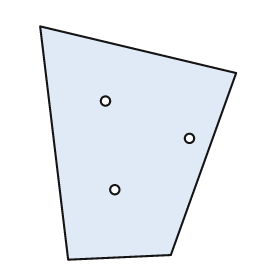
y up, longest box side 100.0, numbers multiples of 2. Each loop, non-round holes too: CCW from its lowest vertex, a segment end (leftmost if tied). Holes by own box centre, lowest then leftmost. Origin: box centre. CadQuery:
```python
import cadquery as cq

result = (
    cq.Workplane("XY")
    .moveTo(-30.0, -50.0)
    .lineTo(14.0, -48.0)
    .lineTo(42.0, 30.0)
    .lineTo(-42.0, 50.0)
    .close()
    .moveTo(-10.0, -20.0)
    .circle(2.0)
    .moveTo(22.0, 2.0)
    .circle(2.0)
    .moveTo(-14.0, 18.0)
    .circle(2.0)
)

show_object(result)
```